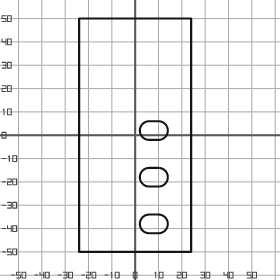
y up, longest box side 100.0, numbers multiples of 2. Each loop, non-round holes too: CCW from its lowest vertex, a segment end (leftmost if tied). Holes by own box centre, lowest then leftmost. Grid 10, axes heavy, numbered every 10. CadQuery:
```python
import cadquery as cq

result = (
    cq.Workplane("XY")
    .moveTo(-24.0, -50.0)
    .lineTo(24.0, -50.0)
    .lineTo(24.0, 50.0)
    .lineTo(-24.0, 50.0)
    .close()
    .moveTo(6.0, -42.0)
    .lineTo(10.0, -42.0)
    .threePointArc((14.0, -38.0), (10.0, -34.0))
    .lineTo(6.0, -34.0)
    .threePointArc((2.0, -38.0), (6.0, -42.0))
    .close()
    .moveTo(6.0, -22.0)
    .lineTo(10.0, -22.0)
    .threePointArc((14.0, -18.0), (10.0, -14.0))
    .lineTo(6.0, -14.0)
    .threePointArc((2.0, -18.0), (6.0, -22.0))
    .close()
    .moveTo(6.0, -2.0)
    .lineTo(10.0, -2.0)
    .threePointArc((14.0, 2.0), (10.0, 6.0))
    .lineTo(6.0, 6.0)
    .threePointArc((2.0, 2.0), (6.0, -2.0))
    .close()
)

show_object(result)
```